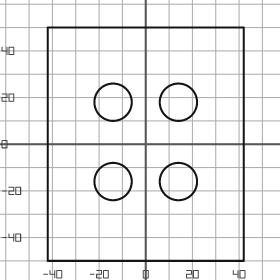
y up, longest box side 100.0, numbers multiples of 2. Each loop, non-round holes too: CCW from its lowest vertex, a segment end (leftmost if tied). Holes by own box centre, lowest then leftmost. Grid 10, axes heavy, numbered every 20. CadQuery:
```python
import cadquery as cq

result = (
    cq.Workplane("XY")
    .moveTo(-42.0, -50.0)
    .lineTo(42.0, -50.0)
    .lineTo(42.0, 50.0)
    .lineTo(-42.0, 50.0)
    .close()
    .moveTo(-14.0, -16.0)
    .circle(8.0)
    .moveTo(14.0, -16.0)
    .circle(8.0)
    .moveTo(-14.0, 18.0)
    .circle(8.0)
    .moveTo(14.0, 18.0)
    .circle(8.0)
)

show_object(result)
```